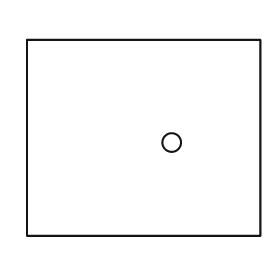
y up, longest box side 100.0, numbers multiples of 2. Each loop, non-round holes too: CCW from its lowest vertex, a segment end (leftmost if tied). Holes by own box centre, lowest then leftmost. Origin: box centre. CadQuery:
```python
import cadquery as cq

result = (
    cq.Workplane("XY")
    .moveTo(-50.0, -42.0)
    .lineTo(50.0, -42.0)
    .lineTo(50.0, 42.0)
    .lineTo(-50.0, 42.0)
    .close()
    .moveTo(12.0, -2.0)
    .circle(4.0)
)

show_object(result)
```